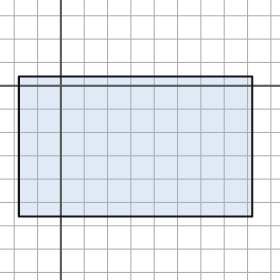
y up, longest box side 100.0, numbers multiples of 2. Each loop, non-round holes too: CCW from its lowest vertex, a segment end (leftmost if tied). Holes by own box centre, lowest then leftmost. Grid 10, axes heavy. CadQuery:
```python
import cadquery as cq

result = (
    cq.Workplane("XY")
    .moveTo(-18.0, -56.0)
    .lineTo(82.0, -56.0)
    .lineTo(82.0, 4.0)
    .lineTo(-18.0, 4.0)
    .close()
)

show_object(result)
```